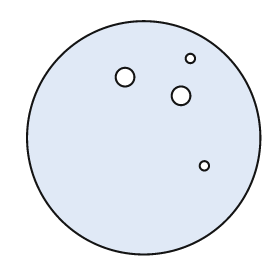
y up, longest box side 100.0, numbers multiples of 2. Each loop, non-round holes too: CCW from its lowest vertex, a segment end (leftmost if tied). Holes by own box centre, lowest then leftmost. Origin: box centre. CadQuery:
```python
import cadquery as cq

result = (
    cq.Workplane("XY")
    .moveTo(0.0, 0.0)
    .circle(50.0)
    .moveTo(26.0, -12.0)
    .circle(2.0)
    .moveTo(16.0, 18.0)
    .circle(4.0)
    .moveTo(-8.0, 26.0)
    .circle(4.0)
    .moveTo(20.0, 34.0)
    .circle(2.0)
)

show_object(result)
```